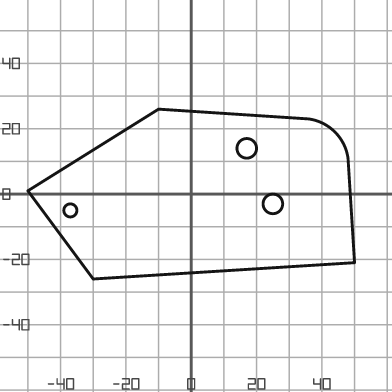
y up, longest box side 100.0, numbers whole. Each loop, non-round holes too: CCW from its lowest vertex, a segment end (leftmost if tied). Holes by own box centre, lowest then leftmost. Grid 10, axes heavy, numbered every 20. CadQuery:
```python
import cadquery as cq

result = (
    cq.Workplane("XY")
    .moveTo(-30.0, -26.0)
    .lineTo(50.0, -21.0)
    .lineTo(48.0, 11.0)
    .threePointArc((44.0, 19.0), (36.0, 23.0))
    .lineTo(-10.0, 26.0)
    .lineTo(-50.0, 1.0)
    .close()
    .moveTo(-37.0, -5.0)
    .circle(2.0)
    .moveTo(25.0, -3.0)
    .circle(3.0)
    .moveTo(17.0, 14.0)
    .circle(3.0)
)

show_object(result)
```